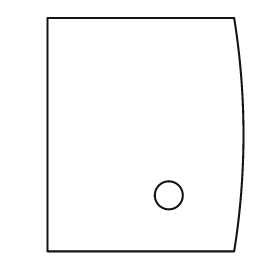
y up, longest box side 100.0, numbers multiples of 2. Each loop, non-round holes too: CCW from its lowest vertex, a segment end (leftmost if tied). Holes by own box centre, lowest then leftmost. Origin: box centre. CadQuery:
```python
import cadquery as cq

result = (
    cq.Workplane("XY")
    .moveTo(-42.0, -50.0)
    .lineTo(38.0, -50.0)
    .threePointArc((42.0, 0.0), (38.0, 50.0))
    .lineTo(-42.0, 50.0)
    .close()
    .moveTo(10.0, -26.0)
    .circle(6.0)
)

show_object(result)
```